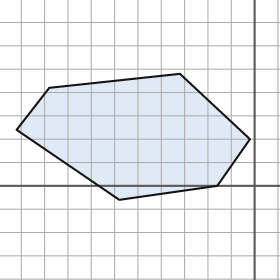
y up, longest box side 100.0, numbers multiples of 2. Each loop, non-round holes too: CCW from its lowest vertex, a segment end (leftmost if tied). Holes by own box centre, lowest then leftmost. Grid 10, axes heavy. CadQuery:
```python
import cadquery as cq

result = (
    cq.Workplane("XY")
    .moveTo(-58.0, -6.0)
    .lineTo(-16.0, 0.0)
    .lineTo(-2.0, 20.0)
    .lineTo(-32.0, 48.0)
    .lineTo(-88.0, 42.0)
    .lineTo(-102.0, 24.0)
    .close()
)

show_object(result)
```